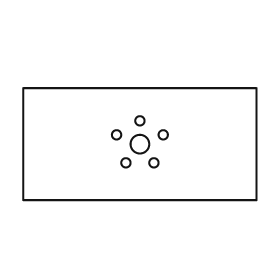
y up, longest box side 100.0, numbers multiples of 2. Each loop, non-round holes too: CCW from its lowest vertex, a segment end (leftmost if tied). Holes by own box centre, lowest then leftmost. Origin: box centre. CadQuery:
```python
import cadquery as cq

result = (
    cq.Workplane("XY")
    .moveTo(-50.0, -24.0)
    .lineTo(50.0, -24.0)
    .lineTo(50.0, 24.0)
    .lineTo(-50.0, 24.0)
    .close()
    .moveTo(-6.0, -8.0)
    .circle(2.0)
    .moveTo(6.0, -8.0)
    .circle(2.0)
    .moveTo(0.0, 0.0)
    .circle(4.0)
    .moveTo(-10.0, 4.0)
    .circle(2.0)
    .moveTo(10.0, 4.0)
    .circle(2.0)
    .moveTo(0.0, 10.0)
    .circle(2.0)
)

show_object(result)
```